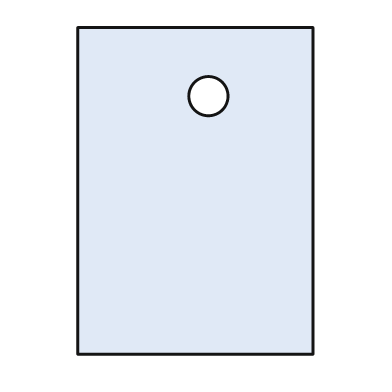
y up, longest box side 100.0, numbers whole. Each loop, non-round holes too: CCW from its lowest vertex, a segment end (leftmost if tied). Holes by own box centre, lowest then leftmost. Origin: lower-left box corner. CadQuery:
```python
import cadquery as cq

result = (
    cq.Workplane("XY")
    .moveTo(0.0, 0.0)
    .lineTo(72.0, 0.0)
    .lineTo(72.0, 100.0)
    .lineTo(0.0, 100.0)
    .close()
    .moveTo(40.0, 79.0)
    .circle(6.0)
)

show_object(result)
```